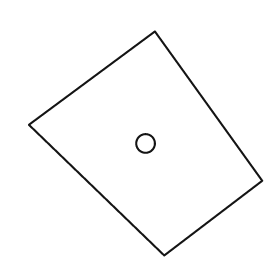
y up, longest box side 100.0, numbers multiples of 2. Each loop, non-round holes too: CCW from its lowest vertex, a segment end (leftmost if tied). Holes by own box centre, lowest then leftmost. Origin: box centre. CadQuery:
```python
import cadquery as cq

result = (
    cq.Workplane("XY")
    .moveTo(8.0, -48.0)
    .lineTo(50.0, -16.0)
    .lineTo(4.0, 48.0)
    .lineTo(-50.0, 8.0)
    .close()
    .moveTo(0.0, 0.0)
    .circle(4.0)
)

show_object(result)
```